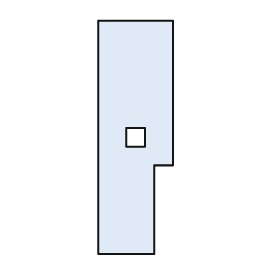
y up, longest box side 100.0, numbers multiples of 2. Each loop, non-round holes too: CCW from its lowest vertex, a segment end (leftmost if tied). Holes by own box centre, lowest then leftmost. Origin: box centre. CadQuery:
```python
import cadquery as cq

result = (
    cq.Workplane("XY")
    .moveTo(-16.0, -50.0)
    .lineTo(8.0, -50.0)
    .lineTo(8.0, -12.0)
    .lineTo(16.0, -12.0)
    .lineTo(16.0, 50.0)
    .lineTo(-16.0, 50.0)
    .close()
    .moveTo(-4.0, -4.0)
    .lineTo(4.0, -4.0)
    .lineTo(4.0, 4.0)
    .lineTo(-4.0, 4.0)
    .close()
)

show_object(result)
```